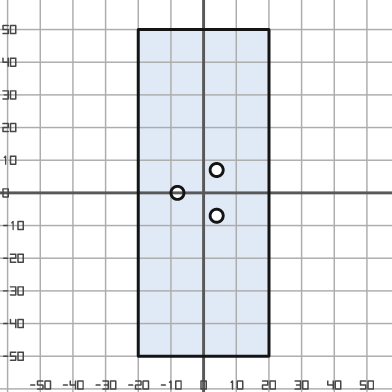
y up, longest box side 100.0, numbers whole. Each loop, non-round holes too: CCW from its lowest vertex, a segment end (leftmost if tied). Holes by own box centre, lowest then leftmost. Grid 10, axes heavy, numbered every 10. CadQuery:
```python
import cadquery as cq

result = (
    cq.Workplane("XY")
    .moveTo(-20.0, -50.0)
    .lineTo(20.0, -50.0)
    .lineTo(20.0, 50.0)
    .lineTo(-20.0, 50.0)
    .close()
    .moveTo(4.0, -7.0)
    .circle(2.0)
    .moveTo(-8.0, 0.0)
    .circle(2.0)
    .moveTo(4.0, 7.0)
    .circle(2.0)
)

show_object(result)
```